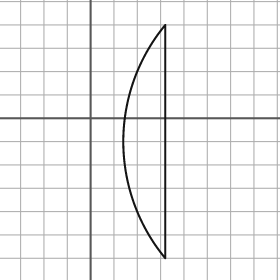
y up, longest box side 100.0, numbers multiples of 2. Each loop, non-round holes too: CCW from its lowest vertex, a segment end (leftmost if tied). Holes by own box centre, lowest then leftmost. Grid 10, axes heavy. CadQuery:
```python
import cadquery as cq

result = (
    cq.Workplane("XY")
    .moveTo(32.0, -60.0)
    .lineTo(32.0, 40.0)
    .threePointArc((14.0, -10.0), (32.0, -60.0))
    .close()
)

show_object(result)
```